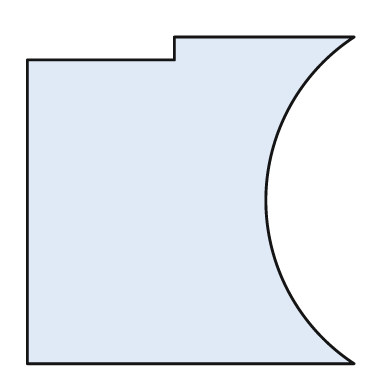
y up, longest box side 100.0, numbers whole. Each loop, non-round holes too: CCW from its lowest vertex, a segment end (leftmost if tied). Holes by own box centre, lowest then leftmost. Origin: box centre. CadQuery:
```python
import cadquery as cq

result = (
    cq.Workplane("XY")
    .moveTo(-50.0, -50.0)
    .lineTo(50.0, -50.0)
    .threePointArc((23.0, 0.0), (50.0, 50.0))
    .lineTo(-5.0, 50.0)
    .lineTo(-5.0, 43.0)
    .lineTo(-50.0, 43.0)
    .close()
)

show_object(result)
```